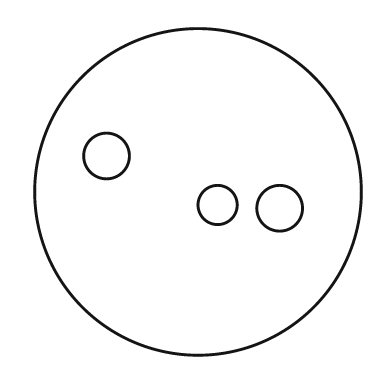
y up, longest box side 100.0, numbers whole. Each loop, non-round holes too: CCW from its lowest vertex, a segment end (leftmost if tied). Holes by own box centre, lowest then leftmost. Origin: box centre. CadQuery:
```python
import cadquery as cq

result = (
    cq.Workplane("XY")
    .moveTo(0.0, 0.0)
    .circle(50.0)
    .moveTo(25.0, -5.0)
    .circle(7.0)
    .moveTo(6.0, -4.0)
    .circle(6.0)
    .moveTo(-28.0, 11.0)
    .circle(7.0)
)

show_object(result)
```